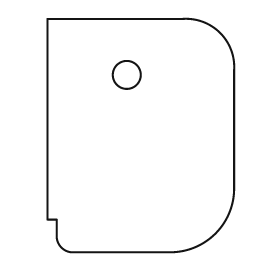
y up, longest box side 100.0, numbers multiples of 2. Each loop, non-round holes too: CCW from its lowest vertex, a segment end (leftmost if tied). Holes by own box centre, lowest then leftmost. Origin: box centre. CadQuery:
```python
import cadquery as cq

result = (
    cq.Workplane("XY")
    .moveTo(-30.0, -50.0)
    .lineTo(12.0, -50.0)
    .threePointArc((32.0, -42.0), (40.0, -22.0))
    .lineTo(40.0, 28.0)
    .threePointArc((34.0, 44.0), (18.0, 50.0))
    .lineTo(-40.0, 50.0)
    .lineTo(-40.0, -36.0)
    .lineTo(-36.0, -36.0)
    .lineTo(-36.0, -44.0)
    .threePointArc((-34.0, -48.0), (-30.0, -50.0))
    .close()
    .moveTo(-6.0, 26.0)
    .circle(6.0)
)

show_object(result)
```